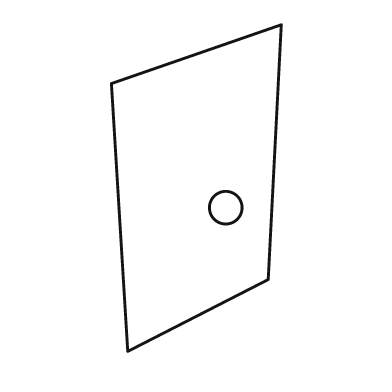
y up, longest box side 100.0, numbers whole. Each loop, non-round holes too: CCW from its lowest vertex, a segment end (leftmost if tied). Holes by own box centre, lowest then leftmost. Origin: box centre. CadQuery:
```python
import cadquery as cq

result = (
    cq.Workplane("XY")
    .moveTo(-21.0, -50.0)
    .lineTo(22.0, -28.0)
    .lineTo(26.0, 50.0)
    .lineTo(-26.0, 32.0)
    .close()
    .moveTo(9.0, -6.0)
    .circle(5.0)
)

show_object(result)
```